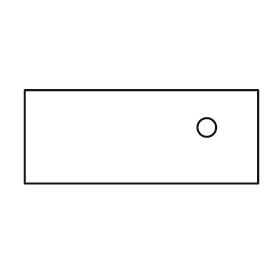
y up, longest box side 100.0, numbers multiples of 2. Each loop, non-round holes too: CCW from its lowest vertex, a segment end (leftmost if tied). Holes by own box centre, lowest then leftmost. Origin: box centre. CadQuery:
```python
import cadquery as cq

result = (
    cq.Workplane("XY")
    .moveTo(-50.0, -20.0)
    .lineTo(50.0, -20.0)
    .lineTo(50.0, 20.0)
    .lineTo(-50.0, 20.0)
    .close()
    .moveTo(28.0, 4.0)
    .circle(4.0)
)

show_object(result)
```